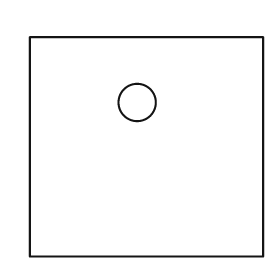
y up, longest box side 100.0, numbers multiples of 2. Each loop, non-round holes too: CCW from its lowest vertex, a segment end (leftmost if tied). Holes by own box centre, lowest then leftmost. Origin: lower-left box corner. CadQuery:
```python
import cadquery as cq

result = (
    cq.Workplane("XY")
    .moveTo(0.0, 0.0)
    .lineTo(100.0, 0.0)
    .lineTo(100.0, 94.0)
    .lineTo(0.0, 94.0)
    .close()
    .moveTo(46.0, 66.0)
    .circle(8.0)
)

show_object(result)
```